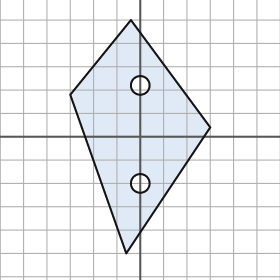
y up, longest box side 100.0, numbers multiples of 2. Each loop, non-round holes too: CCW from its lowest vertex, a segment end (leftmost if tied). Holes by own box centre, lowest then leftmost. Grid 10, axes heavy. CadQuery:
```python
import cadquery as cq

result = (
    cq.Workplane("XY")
    .moveTo(-6.0, -50.0)
    .lineTo(30.0, 4.0)
    .lineTo(-4.0, 50.0)
    .lineTo(-30.0, 18.0)
    .close()
    .moveTo(0.0, -20.0)
    .circle(4.0)
    .moveTo(0.0, 22.0)
    .circle(4.0)
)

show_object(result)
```